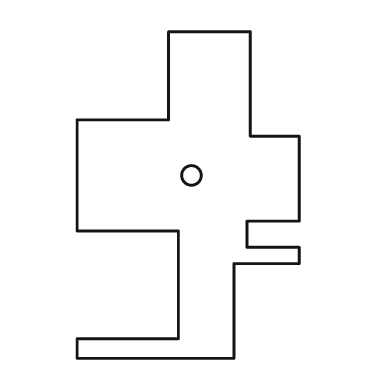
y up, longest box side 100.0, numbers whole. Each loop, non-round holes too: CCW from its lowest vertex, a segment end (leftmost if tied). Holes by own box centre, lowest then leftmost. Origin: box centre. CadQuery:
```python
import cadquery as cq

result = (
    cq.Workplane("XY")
    .moveTo(-34.0, -50.0)
    .lineTo(14.0, -50.0)
    .lineTo(14.0, -21.0)
    .lineTo(34.0, -21.0)
    .lineTo(34.0, -16.0)
    .lineTo(18.0, -16.0)
    .lineTo(18.0, -8.0)
    .lineTo(34.0, -8.0)
    .lineTo(34.0, 18.0)
    .lineTo(19.0, 18.0)
    .lineTo(19.0, 50.0)
    .lineTo(-6.0, 50.0)
    .lineTo(-6.0, 23.0)
    .lineTo(-34.0, 23.0)
    .lineTo(-34.0, -11.0)
    .lineTo(-3.0, -11.0)
    .lineTo(-3.0, -44.0)
    .lineTo(-34.0, -44.0)
    .close()
    .moveTo(1.0, 6.0)
    .circle(3.0)
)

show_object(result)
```